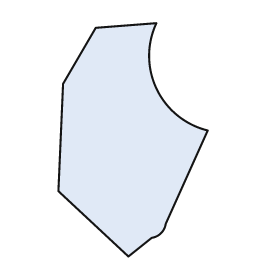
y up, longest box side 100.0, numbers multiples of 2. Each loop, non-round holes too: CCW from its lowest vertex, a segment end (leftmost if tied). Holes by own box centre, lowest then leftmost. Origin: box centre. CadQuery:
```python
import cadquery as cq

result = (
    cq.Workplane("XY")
    .moveTo(-2.0, -50.0)
    .lineTo(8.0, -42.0)
    .threePointArc((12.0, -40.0), (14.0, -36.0))
    .lineTo(32.0, 4.0)
    .threePointArc((10.0, 22.0), (10.0, 50.0))
    .lineTo(-16.0, 48.0)
    .lineTo(-30.0, 24.0)
    .lineTo(-32.0, -22.0)
    .close()
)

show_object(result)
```